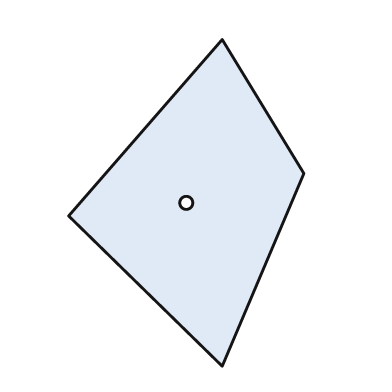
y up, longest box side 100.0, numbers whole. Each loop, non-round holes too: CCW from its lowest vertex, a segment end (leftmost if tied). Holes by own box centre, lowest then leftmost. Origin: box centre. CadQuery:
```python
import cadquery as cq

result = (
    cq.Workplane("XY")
    .moveTo(11.0, -50.0)
    .lineTo(36.0, 9.0)
    .lineTo(11.0, 50.0)
    .lineTo(-36.0, -4.0)
    .close()
    .moveTo(0.0, 0.0)
    .circle(2.0)
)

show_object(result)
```